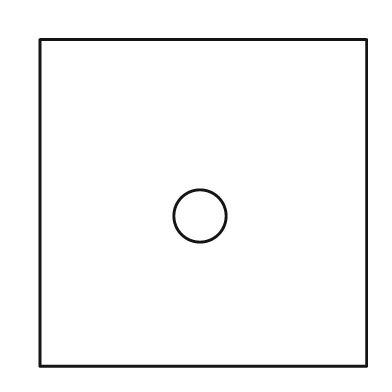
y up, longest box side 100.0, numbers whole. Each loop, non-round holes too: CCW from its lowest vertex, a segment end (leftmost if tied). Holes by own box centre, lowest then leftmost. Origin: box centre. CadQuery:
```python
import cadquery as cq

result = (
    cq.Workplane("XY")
    .moveTo(-50.0, -50.0)
    .lineTo(50.0, -50.0)
    .lineTo(50.0, 50.0)
    .lineTo(-50.0, 50.0)
    .close()
    .moveTo(-1.0, -4.0)
    .circle(8.0)
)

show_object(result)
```